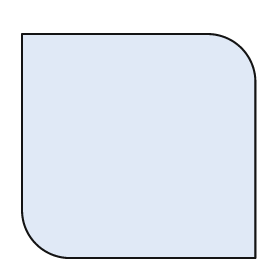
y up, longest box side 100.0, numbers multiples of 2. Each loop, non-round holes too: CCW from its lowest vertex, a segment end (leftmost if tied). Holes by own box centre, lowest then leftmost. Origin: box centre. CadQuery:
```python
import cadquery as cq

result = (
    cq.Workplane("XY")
    .moveTo(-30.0, -48.0)
    .lineTo(50.0, -48.0)
    .lineTo(50.0, 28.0)
    .threePointArc((44.0, 42.0), (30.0, 48.0))
    .lineTo(-50.0, 48.0)
    .lineTo(-50.0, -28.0)
    .threePointArc((-44.0, -42.0), (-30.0, -48.0))
    .close()
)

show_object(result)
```